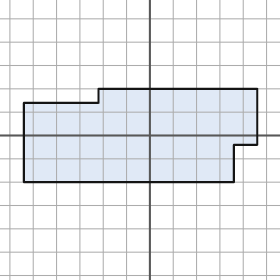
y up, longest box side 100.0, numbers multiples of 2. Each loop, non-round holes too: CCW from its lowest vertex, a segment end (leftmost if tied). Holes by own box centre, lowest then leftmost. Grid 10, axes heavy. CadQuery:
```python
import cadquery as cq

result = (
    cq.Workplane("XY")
    .moveTo(-54.0, -20.0)
    .lineTo(36.0, -20.0)
    .lineTo(36.0, -4.0)
    .lineTo(46.0, -4.0)
    .lineTo(46.0, 20.0)
    .lineTo(-22.0, 20.0)
    .lineTo(-22.0, 14.0)
    .lineTo(-54.0, 14.0)
    .close()
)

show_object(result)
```